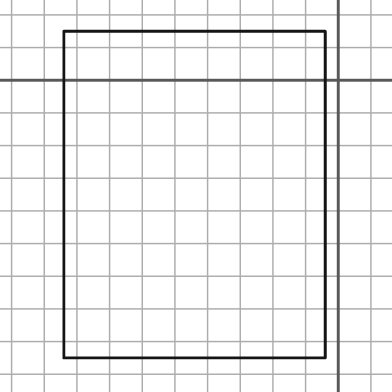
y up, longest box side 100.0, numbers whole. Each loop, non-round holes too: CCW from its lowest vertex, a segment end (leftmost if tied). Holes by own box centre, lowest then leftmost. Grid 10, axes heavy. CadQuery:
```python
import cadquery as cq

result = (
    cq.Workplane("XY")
    .moveTo(-84.0, -85.0)
    .lineTo(-4.0, -85.0)
    .lineTo(-4.0, 15.0)
    .lineTo(-84.0, 15.0)
    .close()
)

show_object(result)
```